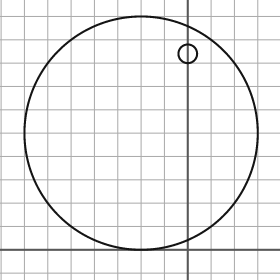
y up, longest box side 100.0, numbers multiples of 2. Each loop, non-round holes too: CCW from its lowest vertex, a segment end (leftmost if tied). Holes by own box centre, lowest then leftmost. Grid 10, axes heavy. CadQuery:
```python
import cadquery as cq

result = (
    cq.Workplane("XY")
    .moveTo(-20.0, 50.0)
    .circle(50.0)
    .moveTo(0.0, 84.0)
    .circle(4.0)
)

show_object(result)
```